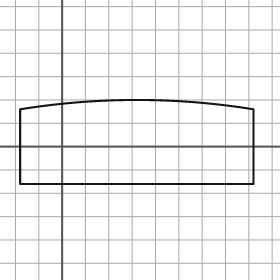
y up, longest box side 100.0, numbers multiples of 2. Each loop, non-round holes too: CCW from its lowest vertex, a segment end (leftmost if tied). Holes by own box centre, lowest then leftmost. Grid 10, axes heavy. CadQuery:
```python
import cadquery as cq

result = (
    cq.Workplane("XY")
    .moveTo(-18.0, -16.0)
    .lineTo(82.0, -16.0)
    .lineTo(82.0, 16.0)
    .threePointArc((32.0, 20.0), (-18.0, 16.0))
    .close()
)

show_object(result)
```